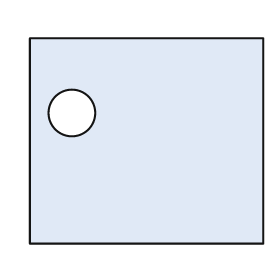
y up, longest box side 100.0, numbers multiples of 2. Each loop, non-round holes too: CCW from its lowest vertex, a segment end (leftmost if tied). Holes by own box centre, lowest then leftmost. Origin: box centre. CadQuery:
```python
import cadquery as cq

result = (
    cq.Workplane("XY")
    .moveTo(-50.0, -44.0)
    .lineTo(50.0, -44.0)
    .lineTo(50.0, 44.0)
    .lineTo(-50.0, 44.0)
    .close()
    .moveTo(-32.0, 12.0)
    .circle(10.0)
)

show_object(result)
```